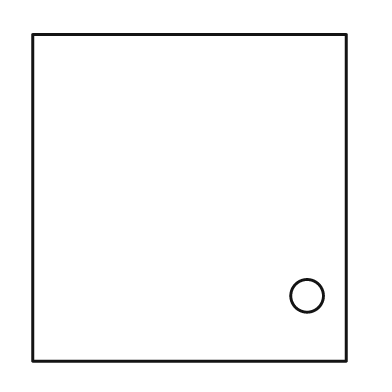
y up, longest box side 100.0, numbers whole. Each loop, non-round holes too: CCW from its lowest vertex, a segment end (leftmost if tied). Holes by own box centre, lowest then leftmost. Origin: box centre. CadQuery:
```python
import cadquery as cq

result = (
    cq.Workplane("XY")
    .moveTo(-48.0, -50.0)
    .lineTo(48.0, -50.0)
    .lineTo(48.0, 50.0)
    .lineTo(-48.0, 50.0)
    .close()
    .moveTo(36.0, -30.0)
    .circle(5.0)
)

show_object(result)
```